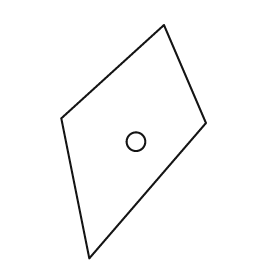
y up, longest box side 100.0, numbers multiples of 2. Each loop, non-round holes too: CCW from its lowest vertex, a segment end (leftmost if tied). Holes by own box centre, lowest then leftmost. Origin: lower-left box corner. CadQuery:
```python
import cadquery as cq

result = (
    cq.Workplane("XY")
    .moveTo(12.0, 0.0)
    .lineTo(62.0, 58.0)
    .lineTo(44.0, 100.0)
    .lineTo(0.0, 60.0)
    .close()
    .moveTo(32.0, 50.0)
    .circle(4.0)
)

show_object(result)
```